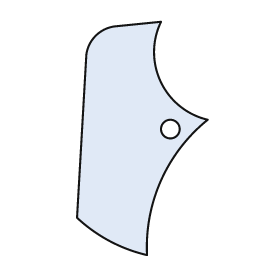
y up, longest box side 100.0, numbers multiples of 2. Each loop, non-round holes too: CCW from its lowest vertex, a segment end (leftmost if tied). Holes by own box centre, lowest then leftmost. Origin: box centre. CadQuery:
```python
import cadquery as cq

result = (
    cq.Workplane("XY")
    .moveTo(2.0, -50.0)
    .threePointArc((8.0, -18.0), (28.0, 8.0))
    .threePointArc((8.0, 24.0), (8.0, 50.0))
    .lineTo(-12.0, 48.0)
    .threePointArc((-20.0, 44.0), (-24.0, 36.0))
    .lineTo(-28.0, -34.0)
    .threePointArc((-14.0, -44.0), (2.0, -50.0))
    .close()
    .moveTo(12.0, 4.0)
    .circle(4.0)
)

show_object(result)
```